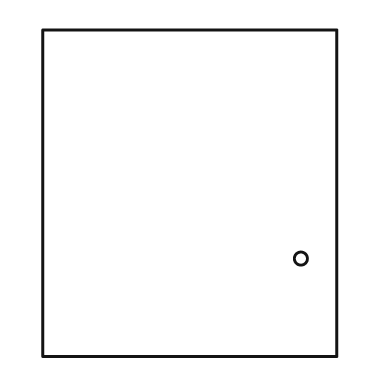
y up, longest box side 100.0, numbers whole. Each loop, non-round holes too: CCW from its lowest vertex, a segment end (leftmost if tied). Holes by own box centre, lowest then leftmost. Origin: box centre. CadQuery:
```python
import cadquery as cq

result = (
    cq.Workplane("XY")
    .moveTo(-45.0, -50.0)
    .lineTo(45.0, -50.0)
    .lineTo(45.0, 50.0)
    .lineTo(-45.0, 50.0)
    .close()
    .moveTo(34.0, -20.0)
    .circle(2.0)
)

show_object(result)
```